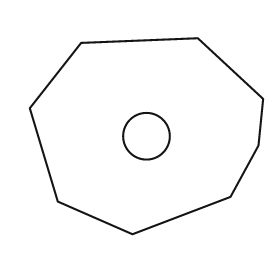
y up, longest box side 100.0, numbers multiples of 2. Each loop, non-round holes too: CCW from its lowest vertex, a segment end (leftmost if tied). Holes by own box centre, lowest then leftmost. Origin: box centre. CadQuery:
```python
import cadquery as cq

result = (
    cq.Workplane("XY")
    .moveTo(-6.0, -42.0)
    .lineTo(36.0, -26.0)
    .lineTo(48.0, -4.0)
    .lineTo(50.0, 16.0)
    .lineTo(22.0, 42.0)
    .lineTo(-28.0, 40.0)
    .lineTo(-50.0, 12.0)
    .lineTo(-38.0, -28.0)
    .close()
    .moveTo(0.0, 0.0)
    .circle(10.0)
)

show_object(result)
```